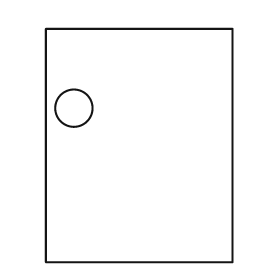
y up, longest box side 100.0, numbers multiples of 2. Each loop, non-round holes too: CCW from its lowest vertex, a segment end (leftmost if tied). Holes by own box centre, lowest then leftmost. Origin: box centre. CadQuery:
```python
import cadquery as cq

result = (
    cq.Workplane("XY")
    .moveTo(-40.0, -50.0)
    .lineTo(40.0, -50.0)
    .lineTo(40.0, 50.0)
    .lineTo(-40.0, 50.0)
    .close()
    .moveTo(-28.0, 16.0)
    .circle(8.0)
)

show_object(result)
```